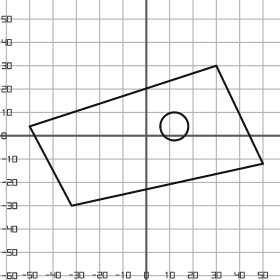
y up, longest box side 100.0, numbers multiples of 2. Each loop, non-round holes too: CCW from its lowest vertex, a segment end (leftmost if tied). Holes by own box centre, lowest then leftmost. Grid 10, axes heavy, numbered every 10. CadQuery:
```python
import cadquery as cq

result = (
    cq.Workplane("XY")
    .moveTo(-32.0, -30.0)
    .lineTo(50.0, -12.0)
    .lineTo(30.0, 30.0)
    .lineTo(-50.0, 4.0)
    .close()
    .moveTo(12.0, 4.0)
    .circle(6.0)
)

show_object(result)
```